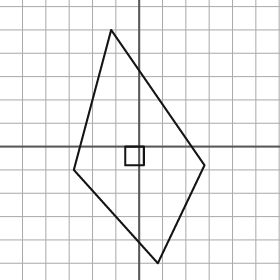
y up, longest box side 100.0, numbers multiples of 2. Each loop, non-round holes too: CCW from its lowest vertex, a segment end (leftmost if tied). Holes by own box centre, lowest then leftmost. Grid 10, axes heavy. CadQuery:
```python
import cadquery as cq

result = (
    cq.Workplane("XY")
    .moveTo(8.0, -50.0)
    .lineTo(28.0, -8.0)
    .lineTo(-12.0, 50.0)
    .lineTo(-28.0, -10.0)
    .close()
    .moveTo(-6.0, -8.0)
    .lineTo(2.0, -8.0)
    .lineTo(2.0, 0.0)
    .lineTo(-6.0, 0.0)
    .close()
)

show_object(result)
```